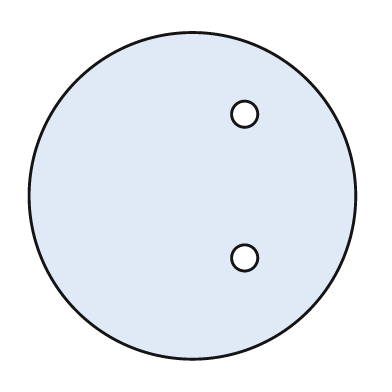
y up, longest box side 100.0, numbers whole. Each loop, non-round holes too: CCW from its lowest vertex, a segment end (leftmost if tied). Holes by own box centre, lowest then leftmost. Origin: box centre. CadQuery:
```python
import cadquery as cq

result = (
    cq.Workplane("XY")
    .moveTo(0.0, 0.0)
    .circle(50.0)
    .moveTo(16.0, -19.0)
    .circle(4.0)
    .moveTo(16.0, 25.0)
    .circle(4.0)
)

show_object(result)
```